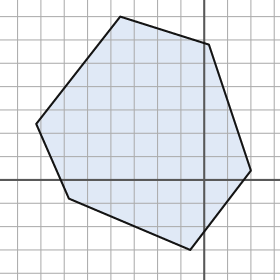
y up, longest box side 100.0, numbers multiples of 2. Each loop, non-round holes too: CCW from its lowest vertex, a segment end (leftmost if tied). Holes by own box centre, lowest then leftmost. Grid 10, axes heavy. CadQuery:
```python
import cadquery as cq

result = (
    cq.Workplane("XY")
    .moveTo(-6.0, -30.0)
    .lineTo(20.0, 4.0)
    .lineTo(2.0, 58.0)
    .lineTo(-36.0, 70.0)
    .lineTo(-72.0, 24.0)
    .lineTo(-58.0, -8.0)
    .close()
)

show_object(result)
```